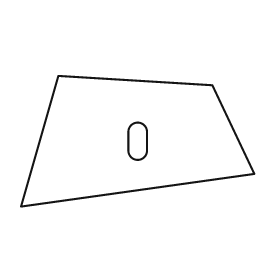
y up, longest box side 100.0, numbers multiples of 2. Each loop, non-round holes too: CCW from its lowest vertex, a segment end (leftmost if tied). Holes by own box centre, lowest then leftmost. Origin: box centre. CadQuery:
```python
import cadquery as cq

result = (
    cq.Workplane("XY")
    .moveTo(-50.0, -28.0)
    .lineTo(50.0, -14.0)
    .lineTo(32.0, 24.0)
    .lineTo(-34.0, 28.0)
    .close()
    .moveTo(-4.0, -4.0)
    .threePointArc((0.0, -8.0), (4.0, -4.0))
    .lineTo(4.0, 4.0)
    .threePointArc((0.0, 8.0), (-4.0, 4.0))
    .close()
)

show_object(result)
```